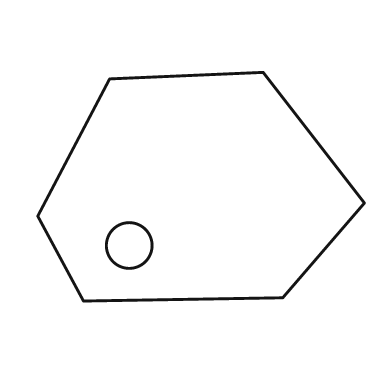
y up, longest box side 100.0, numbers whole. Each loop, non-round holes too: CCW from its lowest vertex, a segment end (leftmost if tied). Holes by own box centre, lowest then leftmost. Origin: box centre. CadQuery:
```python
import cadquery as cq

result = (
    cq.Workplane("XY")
    .moveTo(-36.0, -35.0)
    .lineTo(25.0, -34.0)
    .lineTo(50.0, -5.0)
    .lineTo(19.0, 35.0)
    .lineTo(-28.0, 33.0)
    .lineTo(-50.0, -9.0)
    .close()
    .moveTo(-22.0, -18.0)
    .circle(7.0)
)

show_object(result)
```